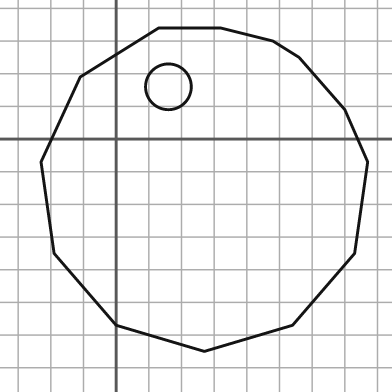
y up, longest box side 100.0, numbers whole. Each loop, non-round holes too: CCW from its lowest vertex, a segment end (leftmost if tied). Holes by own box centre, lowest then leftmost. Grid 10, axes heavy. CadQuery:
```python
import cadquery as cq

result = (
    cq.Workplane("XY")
    .moveTo(27.0, -65.0)
    .lineTo(54.0, -57.0)
    .lineTo(73.0, -35.0)
    .lineTo(77.0, -7.0)
    .lineTo(70.0, 9.0)
    .lineTo(56.0, 25.0)
    .lineTo(48.0, 30.0)
    .lineTo(32.0, 34.0)
    .lineTo(13.0, 34.0)
    .lineTo(-11.0, 19.0)
    .lineTo(-23.0, -7.0)
    .lineTo(-19.0, -35.0)
    .lineTo(0.0, -57.0)
    .close()
    .moveTo(16.0, 16.0)
    .circle(7.0)
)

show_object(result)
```